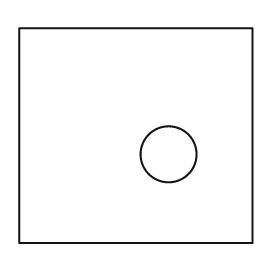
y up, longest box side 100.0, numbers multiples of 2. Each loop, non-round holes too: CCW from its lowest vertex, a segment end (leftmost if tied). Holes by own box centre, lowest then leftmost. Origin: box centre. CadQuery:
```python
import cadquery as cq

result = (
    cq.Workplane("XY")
    .moveTo(-50.0, -46.0)
    .lineTo(50.0, -46.0)
    .lineTo(50.0, 46.0)
    .lineTo(-50.0, 46.0)
    .close()
    .moveTo(14.0, -8.0)
    .circle(12.0)
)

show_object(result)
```